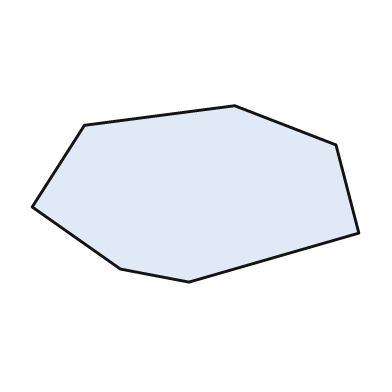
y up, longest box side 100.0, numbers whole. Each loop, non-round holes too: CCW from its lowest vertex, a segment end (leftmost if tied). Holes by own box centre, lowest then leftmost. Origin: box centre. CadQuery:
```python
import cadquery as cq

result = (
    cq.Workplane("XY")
    .moveTo(-2.0, -27.0)
    .lineTo(50.0, -12.0)
    .lineTo(43.0, 15.0)
    .lineTo(12.0, 27.0)
    .lineTo(-34.0, 21.0)
    .lineTo(-50.0, -4.0)
    .lineTo(-23.0, -23.0)
    .close()
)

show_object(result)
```